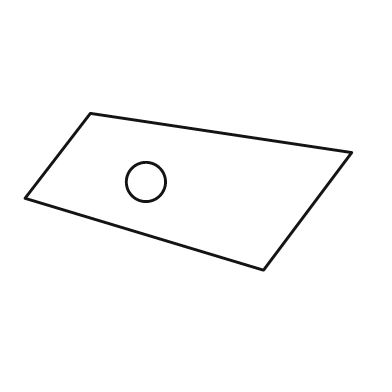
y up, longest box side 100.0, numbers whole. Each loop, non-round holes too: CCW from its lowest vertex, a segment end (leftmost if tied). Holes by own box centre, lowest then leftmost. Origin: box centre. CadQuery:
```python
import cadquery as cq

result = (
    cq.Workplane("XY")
    .moveTo(23.0, -24.0)
    .lineTo(50.0, 12.0)
    .lineTo(-30.0, 24.0)
    .lineTo(-50.0, -2.0)
    .close()
    .moveTo(-13.0, 3.0)
    .circle(6.0)
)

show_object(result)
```